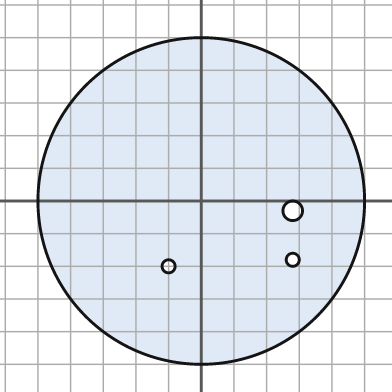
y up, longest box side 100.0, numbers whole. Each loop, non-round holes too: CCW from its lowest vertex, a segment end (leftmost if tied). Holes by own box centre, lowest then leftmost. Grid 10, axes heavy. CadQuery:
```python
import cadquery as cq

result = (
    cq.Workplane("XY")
    .moveTo(0.0, 0.0)
    .circle(50.0)
    .moveTo(-10.0, -20.0)
    .circle(2.0)
    .moveTo(28.0, -18.0)
    .circle(2.0)
    .moveTo(28.0, -3.0)
    .circle(3.0)
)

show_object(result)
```